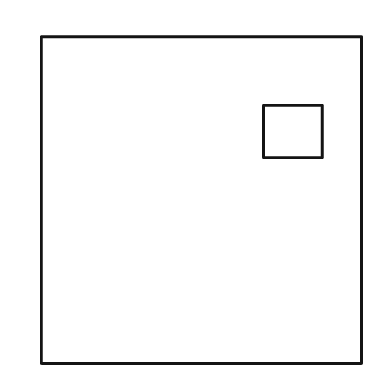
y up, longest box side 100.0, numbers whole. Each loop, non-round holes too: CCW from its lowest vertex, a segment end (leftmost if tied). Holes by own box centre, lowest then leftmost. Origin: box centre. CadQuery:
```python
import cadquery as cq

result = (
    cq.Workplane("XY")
    .moveTo(-49.0, -50.0)
    .lineTo(49.0, -50.0)
    .lineTo(49.0, 50.0)
    .lineTo(-49.0, 50.0)
    .close()
    .moveTo(19.0, 13.0)
    .lineTo(37.0, 13.0)
    .lineTo(37.0, 29.0)
    .lineTo(19.0, 29.0)
    .close()
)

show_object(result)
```